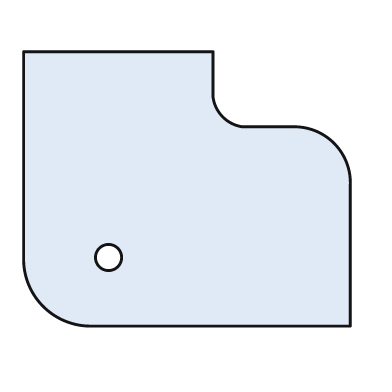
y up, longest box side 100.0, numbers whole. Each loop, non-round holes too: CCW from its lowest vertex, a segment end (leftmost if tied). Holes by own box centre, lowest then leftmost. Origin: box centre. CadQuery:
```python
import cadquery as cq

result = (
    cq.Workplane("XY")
    .moveTo(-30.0, -42.0)
    .lineTo(50.0, -42.0)
    .lineTo(50.0, 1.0)
    .threePointArc((45.0, 14.0), (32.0, 19.0))
    .lineTo(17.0, 19.0)
    .threePointArc((11.0, 22.0), (8.0, 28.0))
    .lineTo(8.0, 42.0)
    .lineTo(-50.0, 42.0)
    .lineTo(-50.0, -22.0)
    .threePointArc((-44.0, -36.0), (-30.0, -42.0))
    .close()
    .moveTo(-24.0, -21.0)
    .circle(4.0)
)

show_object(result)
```